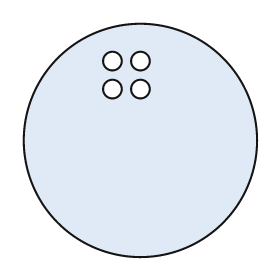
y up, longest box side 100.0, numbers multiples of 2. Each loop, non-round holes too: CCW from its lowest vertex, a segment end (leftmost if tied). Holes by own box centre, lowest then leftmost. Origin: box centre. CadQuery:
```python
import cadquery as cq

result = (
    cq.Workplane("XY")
    .moveTo(0.0, 0.0)
    .circle(50.0)
    .moveTo(-12.0, 22.0)
    .circle(4.0)
    .moveTo(0.0, 22.0)
    .circle(4.0)
    .moveTo(-12.0, 34.0)
    .circle(4.0)
    .moveTo(0.0, 34.0)
    .circle(4.0)
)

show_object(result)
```